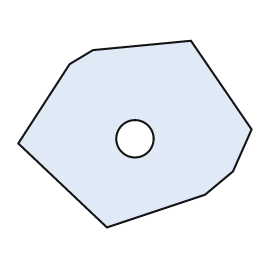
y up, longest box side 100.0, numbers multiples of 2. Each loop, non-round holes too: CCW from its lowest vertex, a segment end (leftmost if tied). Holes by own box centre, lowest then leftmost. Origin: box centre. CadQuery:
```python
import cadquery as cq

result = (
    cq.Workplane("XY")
    .moveTo(-12.0, -40.0)
    .lineTo(30.0, -26.0)
    .lineTo(42.0, -16.0)
    .lineTo(50.0, 2.0)
    .lineTo(24.0, 40.0)
    .lineTo(-18.0, 36.0)
    .lineTo(-28.0, 30.0)
    .lineTo(-50.0, -4.0)
    .close()
    .moveTo(0.0, -2.0)
    .circle(8.0)
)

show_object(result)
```